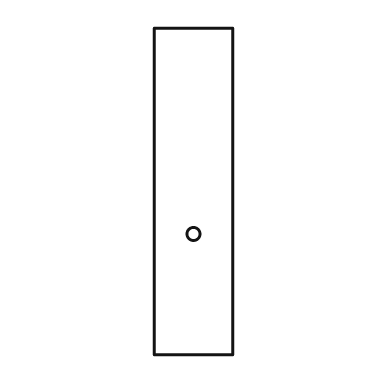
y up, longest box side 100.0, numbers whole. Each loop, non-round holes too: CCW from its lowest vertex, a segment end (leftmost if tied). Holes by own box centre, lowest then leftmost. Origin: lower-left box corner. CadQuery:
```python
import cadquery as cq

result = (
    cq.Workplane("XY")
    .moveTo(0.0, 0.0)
    .lineTo(24.0, 0.0)
    .lineTo(24.0, 100.0)
    .lineTo(0.0, 100.0)
    .close()
    .moveTo(12.0, 37.0)
    .circle(2.0)
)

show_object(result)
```